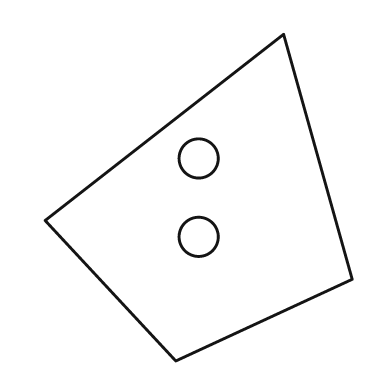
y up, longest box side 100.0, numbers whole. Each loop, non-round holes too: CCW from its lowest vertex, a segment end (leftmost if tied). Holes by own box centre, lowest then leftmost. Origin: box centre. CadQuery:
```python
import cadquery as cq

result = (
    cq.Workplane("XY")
    .moveTo(-7.0, -50.0)
    .lineTo(47.0, -25.0)
    .lineTo(26.0, 50.0)
    .lineTo(-47.0, -7.0)
    .close()
    .moveTo(0.0, -12.0)
    .circle(6.0)
    .moveTo(0.0, 12.0)
    .circle(6.0)
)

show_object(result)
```